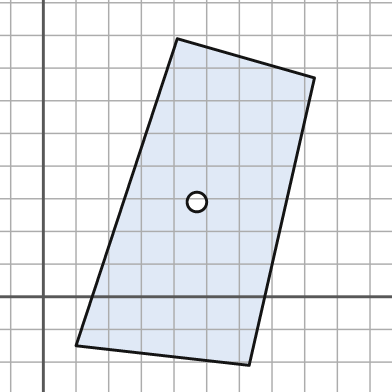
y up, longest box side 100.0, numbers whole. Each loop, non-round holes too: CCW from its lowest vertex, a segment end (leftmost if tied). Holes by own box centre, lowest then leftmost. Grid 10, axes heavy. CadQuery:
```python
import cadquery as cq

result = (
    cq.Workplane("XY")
    .moveTo(63.0, -21.0)
    .lineTo(83.0, 67.0)
    .lineTo(41.0, 79.0)
    .lineTo(10.0, -15.0)
    .close()
    .moveTo(47.0, 29.0)
    .circle(3.0)
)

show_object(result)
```